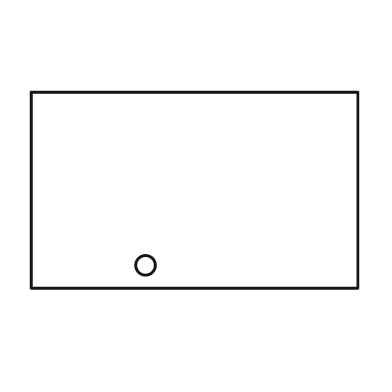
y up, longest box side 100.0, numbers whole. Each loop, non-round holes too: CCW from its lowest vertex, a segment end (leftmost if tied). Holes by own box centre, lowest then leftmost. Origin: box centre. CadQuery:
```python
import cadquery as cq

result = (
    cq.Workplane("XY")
    .moveTo(-50.0, -30.0)
    .lineTo(50.0, -30.0)
    .lineTo(50.0, 30.0)
    .lineTo(-50.0, 30.0)
    .close()
    .moveTo(-15.0, -23.0)
    .circle(3.0)
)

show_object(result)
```